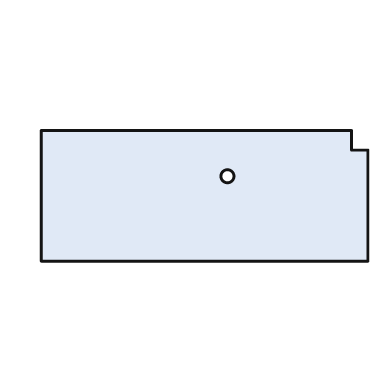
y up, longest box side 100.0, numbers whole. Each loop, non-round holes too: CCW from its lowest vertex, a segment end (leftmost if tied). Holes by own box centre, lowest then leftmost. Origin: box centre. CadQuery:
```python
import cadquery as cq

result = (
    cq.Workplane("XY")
    .moveTo(-50.0, -20.0)
    .lineTo(50.0, -20.0)
    .lineTo(50.0, 14.0)
    .lineTo(45.0, 14.0)
    .lineTo(45.0, 20.0)
    .lineTo(-50.0, 20.0)
    .close()
    .moveTo(7.0, 6.0)
    .circle(2.0)
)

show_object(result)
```